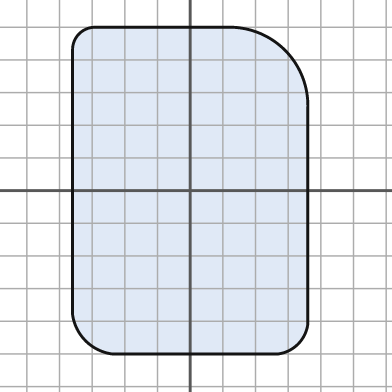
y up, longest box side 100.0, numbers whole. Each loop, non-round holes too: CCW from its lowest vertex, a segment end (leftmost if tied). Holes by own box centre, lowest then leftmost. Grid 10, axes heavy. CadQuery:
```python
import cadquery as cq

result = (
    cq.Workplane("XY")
    .moveTo(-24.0, -50.0)
    .lineTo(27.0, -50.0)
    .threePointArc((33.0, -47.0), (36.0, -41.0))
    .lineTo(36.0, 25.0)
    .threePointArc((29.0, 43.0), (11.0, 50.0))
    .lineTo(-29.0, 50.0)
    .threePointArc((-34.0, 48.0), (-36.0, 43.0))
    .lineTo(-36.0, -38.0)
    .threePointArc((-32.0, -46.0), (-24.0, -50.0))
    .close()
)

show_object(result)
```